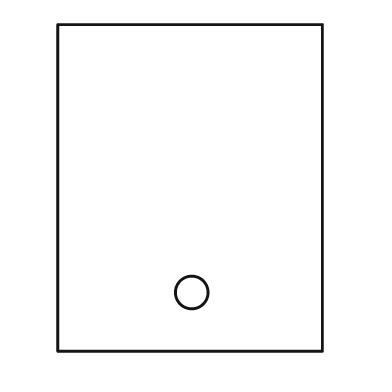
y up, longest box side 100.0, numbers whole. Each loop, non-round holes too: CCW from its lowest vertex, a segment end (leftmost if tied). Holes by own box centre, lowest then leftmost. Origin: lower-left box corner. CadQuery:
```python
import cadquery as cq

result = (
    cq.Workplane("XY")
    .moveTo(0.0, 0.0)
    .lineTo(81.0, 0.0)
    .lineTo(81.0, 100.0)
    .lineTo(0.0, 100.0)
    .close()
    .moveTo(41.0, 18.0)
    .circle(5.0)
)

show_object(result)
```